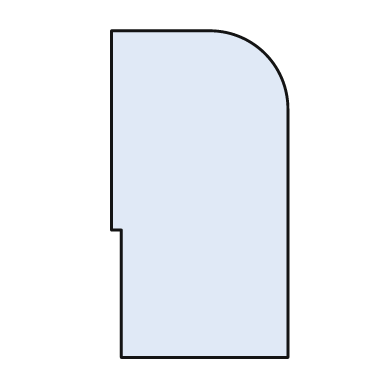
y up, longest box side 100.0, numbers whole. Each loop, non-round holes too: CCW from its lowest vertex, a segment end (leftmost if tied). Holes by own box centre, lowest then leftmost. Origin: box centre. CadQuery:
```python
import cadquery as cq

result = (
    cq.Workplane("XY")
    .moveTo(-24.0, -50.0)
    .lineTo(27.0, -50.0)
    .lineTo(27.0, 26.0)
    .threePointArc((20.0, 43.0), (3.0, 50.0))
    .lineTo(-27.0, 50.0)
    .lineTo(-27.0, -11.0)
    .lineTo(-24.0, -11.0)
    .close()
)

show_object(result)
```